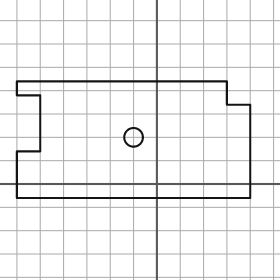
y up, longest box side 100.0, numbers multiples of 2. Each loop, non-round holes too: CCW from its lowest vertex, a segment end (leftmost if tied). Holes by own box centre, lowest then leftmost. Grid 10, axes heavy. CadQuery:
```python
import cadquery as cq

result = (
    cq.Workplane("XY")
    .moveTo(-60.0, -6.0)
    .lineTo(40.0, -6.0)
    .lineTo(40.0, 34.0)
    .lineTo(30.0, 34.0)
    .lineTo(30.0, 44.0)
    .lineTo(-60.0, 44.0)
    .lineTo(-60.0, 38.0)
    .lineTo(-50.0, 38.0)
    .lineTo(-50.0, 14.0)
    .lineTo(-60.0, 14.0)
    .close()
    .moveTo(-10.0, 20.0)
    .circle(4.0)
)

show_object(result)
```